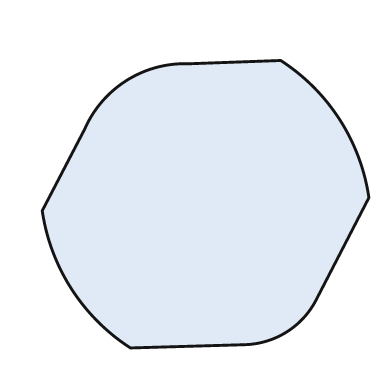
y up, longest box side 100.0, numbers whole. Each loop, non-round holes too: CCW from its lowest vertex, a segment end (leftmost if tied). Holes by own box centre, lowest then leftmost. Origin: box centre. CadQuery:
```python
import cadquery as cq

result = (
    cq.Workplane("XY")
    .moveTo(-23.0, -44.0)
    .lineTo(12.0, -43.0)
    .threePointArc((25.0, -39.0), (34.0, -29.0))
    .lineTo(50.0, 2.0)
    .threePointArc((41.0, 26.0), (23.0, 44.0))
    .lineTo(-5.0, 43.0)
    .threePointArc((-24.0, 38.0), (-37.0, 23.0))
    .lineTo(-50.0, -2.0)
    .threePointArc((-41.0, -26.0), (-23.0, -44.0))
    .close()
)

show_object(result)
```